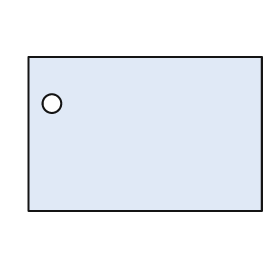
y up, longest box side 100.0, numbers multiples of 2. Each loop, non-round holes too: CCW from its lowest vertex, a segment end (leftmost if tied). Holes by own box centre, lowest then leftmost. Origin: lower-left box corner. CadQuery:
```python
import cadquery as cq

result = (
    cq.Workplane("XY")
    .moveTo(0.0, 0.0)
    .lineTo(100.0, 0.0)
    .lineTo(100.0, 66.0)
    .lineTo(0.0, 66.0)
    .close()
    .moveTo(10.0, 46.0)
    .circle(4.0)
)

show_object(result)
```